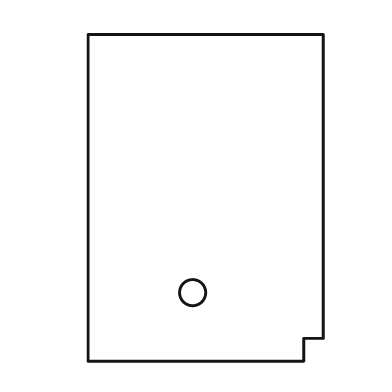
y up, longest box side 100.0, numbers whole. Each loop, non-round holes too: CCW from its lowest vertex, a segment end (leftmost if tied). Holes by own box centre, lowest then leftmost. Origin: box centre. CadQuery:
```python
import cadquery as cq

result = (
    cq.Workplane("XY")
    .moveTo(-36.0, -50.0)
    .lineTo(30.0, -50.0)
    .lineTo(30.0, -43.0)
    .lineTo(36.0, -43.0)
    .lineTo(36.0, 50.0)
    .lineTo(-36.0, 50.0)
    .close()
    .moveTo(-4.0, -29.0)
    .circle(4.0)
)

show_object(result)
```